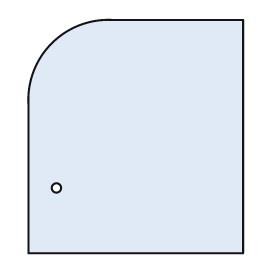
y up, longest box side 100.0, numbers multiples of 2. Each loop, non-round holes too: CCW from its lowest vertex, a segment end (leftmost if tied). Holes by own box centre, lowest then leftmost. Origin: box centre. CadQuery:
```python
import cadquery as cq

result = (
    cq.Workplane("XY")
    .moveTo(-46.0, -50.0)
    .lineTo(46.0, -50.0)
    .lineTo(46.0, 50.0)
    .lineTo(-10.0, 50.0)
    .threePointArc((-36.0, 40.0), (-46.0, 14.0))
    .close()
    .moveTo(-34.0, -22.0)
    .circle(2.0)
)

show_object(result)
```